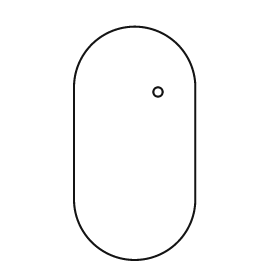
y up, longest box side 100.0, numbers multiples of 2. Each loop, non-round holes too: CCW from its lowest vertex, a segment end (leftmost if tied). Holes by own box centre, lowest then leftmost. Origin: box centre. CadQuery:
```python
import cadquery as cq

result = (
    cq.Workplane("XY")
    .moveTo(-26.0, -24.0)
    .threePointArc((0.0, -50.0), (26.0, -24.0))
    .lineTo(26.0, 24.0)
    .threePointArc((0.0, 50.0), (-26.0, 24.0))
    .close()
    .moveTo(10.0, 22.0)
    .circle(2.0)
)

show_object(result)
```